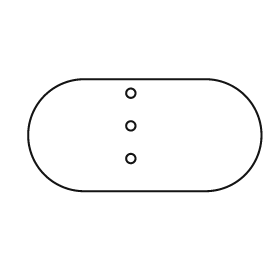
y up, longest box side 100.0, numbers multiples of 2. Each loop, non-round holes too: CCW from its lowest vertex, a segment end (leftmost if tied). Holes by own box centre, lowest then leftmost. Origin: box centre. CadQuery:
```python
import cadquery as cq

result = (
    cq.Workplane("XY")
    .moveTo(-26.0, -24.0)
    .lineTo(26.0, -24.0)
    .threePointArc((50.0, 0.0), (26.0, 24.0))
    .lineTo(-26.0, 24.0)
    .threePointArc((-50.0, 0.0), (-26.0, -24.0))
    .close()
    .moveTo(-6.0, -10.0)
    .circle(2.0)
    .moveTo(-6.0, 4.0)
    .circle(2.0)
    .moveTo(-6.0, 18.0)
    .circle(2.0)
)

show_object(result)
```